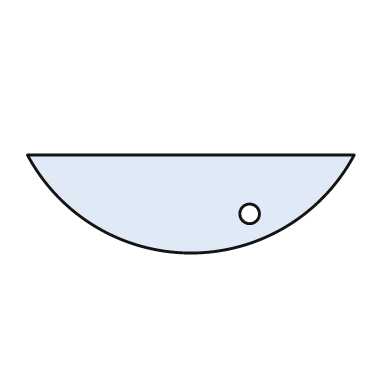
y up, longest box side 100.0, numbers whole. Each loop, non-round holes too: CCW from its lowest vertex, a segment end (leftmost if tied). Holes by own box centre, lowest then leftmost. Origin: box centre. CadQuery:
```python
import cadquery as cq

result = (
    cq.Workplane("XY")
    .moveTo(-50.0, 15.0)
    .threePointArc((0.0, -15.0), (50.0, 15.0))
    .close()
    .moveTo(18.0, -3.0)
    .circle(3.0)
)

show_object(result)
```